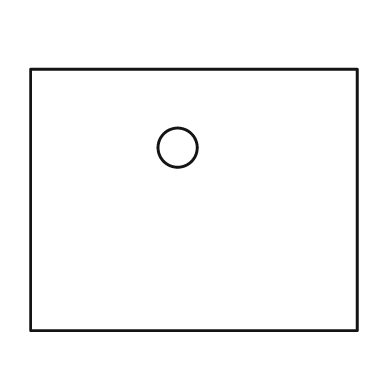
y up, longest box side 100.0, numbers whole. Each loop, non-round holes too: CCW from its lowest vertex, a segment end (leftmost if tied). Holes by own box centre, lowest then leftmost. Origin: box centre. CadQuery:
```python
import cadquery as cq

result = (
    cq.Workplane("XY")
    .moveTo(-50.0, -40.0)
    .lineTo(50.0, -40.0)
    .lineTo(50.0, 40.0)
    .lineTo(-50.0, 40.0)
    .close()
    .moveTo(-5.0, 16.0)
    .circle(6.0)
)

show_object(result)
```